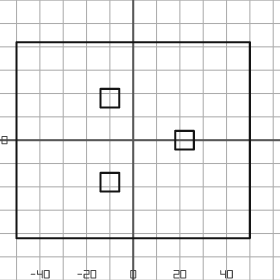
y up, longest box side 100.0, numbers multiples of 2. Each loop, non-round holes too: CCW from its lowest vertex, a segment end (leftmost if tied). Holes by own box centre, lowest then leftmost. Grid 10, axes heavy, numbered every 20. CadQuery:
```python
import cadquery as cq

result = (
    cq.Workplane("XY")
    .moveTo(-50.0, -42.0)
    .lineTo(50.0, -42.0)
    .lineTo(50.0, 42.0)
    .lineTo(-50.0, 42.0)
    .close()
    .moveTo(-14.0, -22.0)
    .lineTo(-6.0, -22.0)
    .lineTo(-6.0, -14.0)
    .lineTo(-14.0, -14.0)
    .close()
    .moveTo(18.0, -4.0)
    .lineTo(26.0, -4.0)
    .lineTo(26.0, 4.0)
    .lineTo(18.0, 4.0)
    .close()
    .moveTo(-14.0, 14.0)
    .lineTo(-6.0, 14.0)
    .lineTo(-6.0, 22.0)
    .lineTo(-14.0, 22.0)
    .close()
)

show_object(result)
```